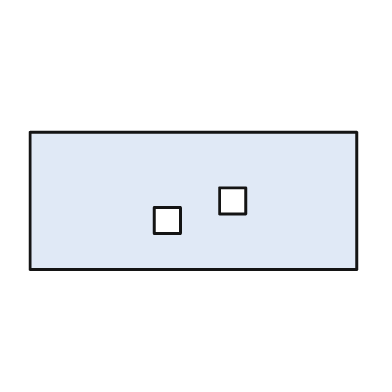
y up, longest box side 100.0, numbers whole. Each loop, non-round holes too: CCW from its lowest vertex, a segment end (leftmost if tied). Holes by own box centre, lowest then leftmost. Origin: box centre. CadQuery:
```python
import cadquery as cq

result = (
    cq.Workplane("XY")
    .moveTo(-50.0, -21.0)
    .lineTo(50.0, -21.0)
    .lineTo(50.0, 21.0)
    .lineTo(-50.0, 21.0)
    .close()
    .moveTo(-12.0, -10.0)
    .lineTo(-4.0, -10.0)
    .lineTo(-4.0, -2.0)
    .lineTo(-12.0, -2.0)
    .close()
    .moveTo(8.0, -4.0)
    .lineTo(16.0, -4.0)
    .lineTo(16.0, 4.0)
    .lineTo(8.0, 4.0)
    .close()
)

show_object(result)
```